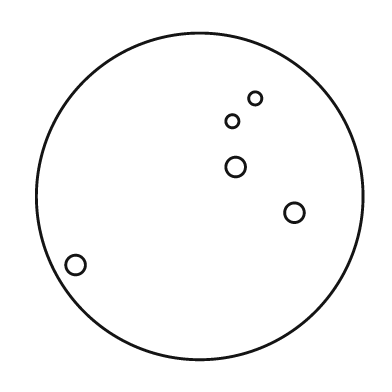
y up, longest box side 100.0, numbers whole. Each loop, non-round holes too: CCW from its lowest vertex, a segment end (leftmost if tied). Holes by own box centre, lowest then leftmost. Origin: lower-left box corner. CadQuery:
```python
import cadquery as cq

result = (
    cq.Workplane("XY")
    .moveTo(50.0, 50.0)
    .circle(50.0)
    .moveTo(12.0, 29.0)
    .circle(3.0)
    .moveTo(79.0, 45.0)
    .circle(3.0)
    .moveTo(61.0, 59.0)
    .circle(3.0)
    .moveTo(60.0, 73.0)
    .circle(2.0)
    .moveTo(67.0, 80.0)
    .circle(2.0)
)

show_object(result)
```